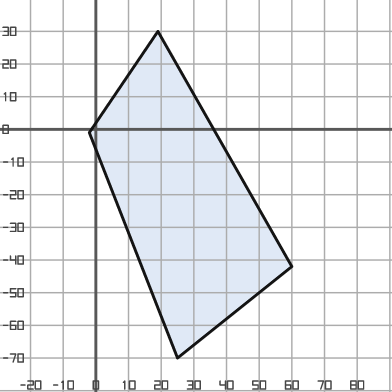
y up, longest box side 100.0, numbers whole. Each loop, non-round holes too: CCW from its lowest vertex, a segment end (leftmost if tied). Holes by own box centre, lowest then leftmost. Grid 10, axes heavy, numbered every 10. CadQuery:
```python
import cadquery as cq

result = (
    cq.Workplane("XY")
    .moveTo(25.0, -70.0)
    .lineTo(60.0, -42.0)
    .lineTo(19.0, 30.0)
    .lineTo(-2.0, -1.0)
    .close()
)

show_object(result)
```